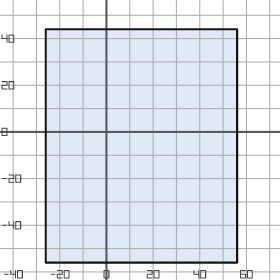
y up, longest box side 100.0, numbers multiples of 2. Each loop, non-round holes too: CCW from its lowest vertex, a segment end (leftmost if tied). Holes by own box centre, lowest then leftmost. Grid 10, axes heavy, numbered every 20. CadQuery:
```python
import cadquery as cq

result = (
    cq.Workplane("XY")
    .moveTo(-26.0, -56.0)
    .lineTo(56.0, -56.0)
    .lineTo(56.0, 44.0)
    .lineTo(-26.0, 44.0)
    .close()
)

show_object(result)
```